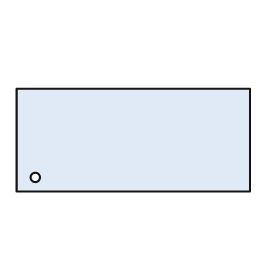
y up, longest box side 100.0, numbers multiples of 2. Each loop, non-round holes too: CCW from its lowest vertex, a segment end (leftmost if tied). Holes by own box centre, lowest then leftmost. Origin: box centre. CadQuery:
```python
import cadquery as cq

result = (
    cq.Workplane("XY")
    .moveTo(-50.0, -22.0)
    .lineTo(50.0, -22.0)
    .lineTo(50.0, 22.0)
    .lineTo(-50.0, 22.0)
    .close()
    .moveTo(-42.0, -16.0)
    .circle(2.0)
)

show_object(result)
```